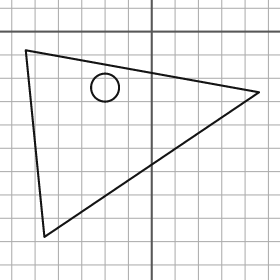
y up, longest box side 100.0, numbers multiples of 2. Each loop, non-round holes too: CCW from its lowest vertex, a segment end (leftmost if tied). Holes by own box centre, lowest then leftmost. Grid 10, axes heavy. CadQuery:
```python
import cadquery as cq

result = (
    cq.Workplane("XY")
    .moveTo(-46.0, -88.0)
    .lineTo(46.0, -26.0)
    .lineTo(-54.0, -8.0)
    .close()
    .moveTo(-20.0, -24.0)
    .circle(6.0)
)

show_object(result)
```